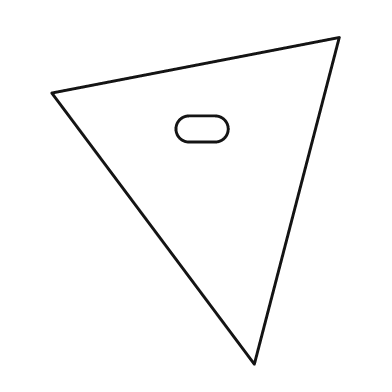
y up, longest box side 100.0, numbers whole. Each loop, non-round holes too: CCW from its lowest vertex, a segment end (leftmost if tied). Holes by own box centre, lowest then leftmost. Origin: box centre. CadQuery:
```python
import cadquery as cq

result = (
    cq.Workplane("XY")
    .moveTo(18.0, -50.0)
    .lineTo(44.0, 50.0)
    .lineTo(-44.0, 33.0)
    .close()
    .moveTo(-2.0, 18.0)
    .lineTo(6.0, 18.0)
    .threePointArc((10.0, 22.0), (6.0, 26.0))
    .lineTo(-2.0, 26.0)
    .threePointArc((-6.0, 22.0), (-2.0, 18.0))
    .close()
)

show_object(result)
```